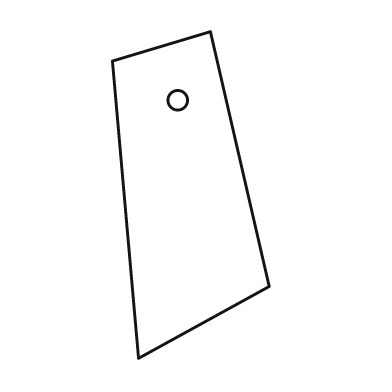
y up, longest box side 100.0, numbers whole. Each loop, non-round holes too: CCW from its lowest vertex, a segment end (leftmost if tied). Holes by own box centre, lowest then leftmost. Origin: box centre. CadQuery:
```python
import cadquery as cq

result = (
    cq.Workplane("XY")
    .moveTo(-16.0, -50.0)
    .lineTo(24.0, -28.0)
    .lineTo(6.0, 50.0)
    .lineTo(-24.0, 41.0)
    .close()
    .moveTo(-4.0, 29.0)
    .circle(3.0)
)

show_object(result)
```